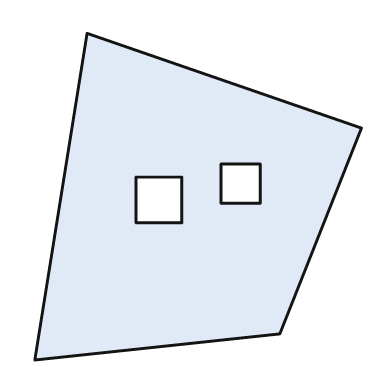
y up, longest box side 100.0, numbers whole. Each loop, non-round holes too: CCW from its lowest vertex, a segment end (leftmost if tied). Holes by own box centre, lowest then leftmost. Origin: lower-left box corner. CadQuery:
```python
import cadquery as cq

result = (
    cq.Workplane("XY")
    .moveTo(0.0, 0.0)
    .lineTo(75.0, 8.0)
    .lineTo(100.0, 71.0)
    .lineTo(16.0, 100.0)
    .close()
    .moveTo(31.0, 42.0)
    .lineTo(45.0, 42.0)
    .lineTo(45.0, 56.0)
    .lineTo(31.0, 56.0)
    .close()
    .moveTo(57.0, 48.0)
    .lineTo(69.0, 48.0)
    .lineTo(69.0, 60.0)
    .lineTo(57.0, 60.0)
    .close()
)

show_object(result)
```